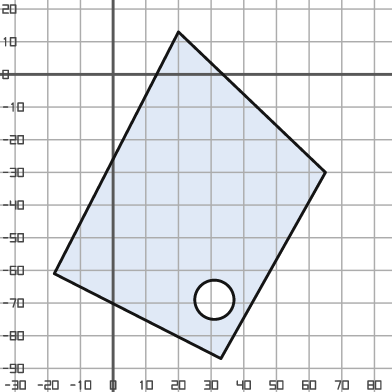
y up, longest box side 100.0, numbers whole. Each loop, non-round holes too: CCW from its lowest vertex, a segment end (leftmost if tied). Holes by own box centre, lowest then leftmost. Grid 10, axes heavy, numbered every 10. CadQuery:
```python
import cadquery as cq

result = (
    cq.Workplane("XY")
    .moveTo(33.0, -87.0)
    .lineTo(65.0, -30.0)
    .lineTo(20.0, 13.0)
    .lineTo(-18.0, -61.0)
    .close()
    .moveTo(31.0, -69.0)
    .circle(6.0)
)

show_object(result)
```